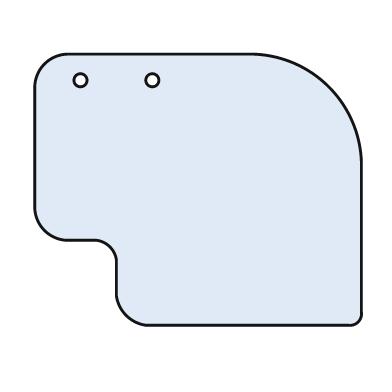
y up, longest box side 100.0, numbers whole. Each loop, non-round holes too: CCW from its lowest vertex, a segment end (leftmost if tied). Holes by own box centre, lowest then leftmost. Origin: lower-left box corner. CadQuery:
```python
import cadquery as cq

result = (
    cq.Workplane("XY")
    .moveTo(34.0, 0.0)
    .lineTo(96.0, 0.0)
    .threePointArc((99.0, 1.0), (100.0, 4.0))
    .lineTo(100.0, 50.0)
    .threePointArc((90.0, 73.0), (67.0, 83.0))
    .lineTo(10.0, 83.0)
    .threePointArc((3.0, 80.0), (0.0, 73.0))
    .lineTo(0.0, 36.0)
    .threePointArc((3.0, 29.0), (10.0, 26.0))
    .lineTo(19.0, 26.0)
    .threePointArc((23.0, 24.0), (25.0, 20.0))
    .lineTo(25.0, 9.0)
    .threePointArc((28.0, 3.0), (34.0, 0.0))
    .close()
    .moveTo(14.0, 75.0)
    .circle(2.0)
    .moveTo(36.0, 75.0)
    .circle(2.0)
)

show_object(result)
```